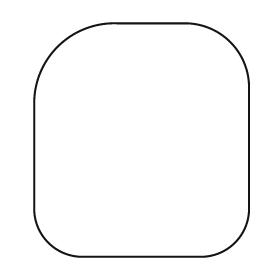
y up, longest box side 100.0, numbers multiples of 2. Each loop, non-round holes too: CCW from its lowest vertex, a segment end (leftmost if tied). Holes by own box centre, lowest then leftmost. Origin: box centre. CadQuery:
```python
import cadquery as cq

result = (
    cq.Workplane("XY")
    .moveTo(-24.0, -50.0)
    .lineTo(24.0, -50.0)
    .threePointArc((40.0, -44.0), (46.0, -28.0))
    .lineTo(46.0, 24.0)
    .threePointArc((38.0, 42.0), (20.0, 50.0))
    .lineTo(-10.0, 50.0)
    .threePointArc((-36.0, 40.0), (-46.0, 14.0))
    .lineTo(-46.0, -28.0)
    .threePointArc((-40.0, -44.0), (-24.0, -50.0))
    .close()
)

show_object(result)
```